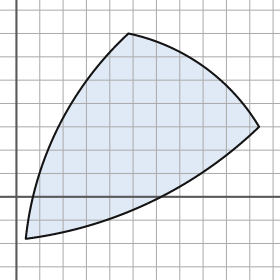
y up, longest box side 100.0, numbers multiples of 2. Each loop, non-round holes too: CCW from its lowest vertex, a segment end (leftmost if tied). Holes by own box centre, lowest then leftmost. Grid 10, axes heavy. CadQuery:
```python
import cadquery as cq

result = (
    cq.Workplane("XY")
    .moveTo(4.0, -18.0)
    .threePointArc((58.0, -2.0), (104.0, 30.0))
    .threePointArc((80.0, 56.0), (48.0, 70.0))
    .threePointArc((18.0, 30.0), (4.0, -18.0))
    .close()
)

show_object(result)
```